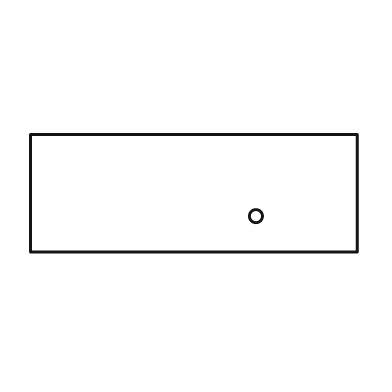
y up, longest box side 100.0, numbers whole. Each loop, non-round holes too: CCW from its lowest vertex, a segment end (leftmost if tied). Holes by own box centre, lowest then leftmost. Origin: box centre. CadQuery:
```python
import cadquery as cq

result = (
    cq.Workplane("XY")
    .moveTo(-50.0, -18.0)
    .lineTo(50.0, -18.0)
    .lineTo(50.0, 18.0)
    .lineTo(-50.0, 18.0)
    .close()
    .moveTo(19.0, -7.0)
    .circle(2.0)
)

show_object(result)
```